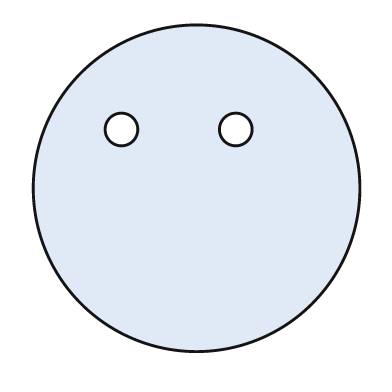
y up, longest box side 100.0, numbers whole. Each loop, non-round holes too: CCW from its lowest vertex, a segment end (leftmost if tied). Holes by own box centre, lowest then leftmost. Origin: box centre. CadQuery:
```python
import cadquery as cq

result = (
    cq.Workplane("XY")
    .moveTo(0.0, 0.0)
    .circle(50.0)
    .moveTo(-23.0, 18.0)
    .circle(5.0)
    .moveTo(12.0, 18.0)
    .circle(5.0)
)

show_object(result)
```